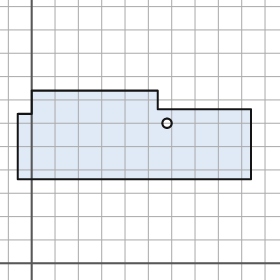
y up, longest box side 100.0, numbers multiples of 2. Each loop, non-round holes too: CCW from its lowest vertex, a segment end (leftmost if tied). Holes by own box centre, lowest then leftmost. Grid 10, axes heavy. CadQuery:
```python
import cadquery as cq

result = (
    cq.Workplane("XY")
    .moveTo(-6.0, 36.0)
    .lineTo(94.0, 36.0)
    .lineTo(94.0, 66.0)
    .lineTo(54.0, 66.0)
    .lineTo(54.0, 74.0)
    .lineTo(0.0, 74.0)
    .lineTo(0.0, 64.0)
    .lineTo(-6.0, 64.0)
    .close()
    .moveTo(58.0, 60.0)
    .circle(2.0)
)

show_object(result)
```